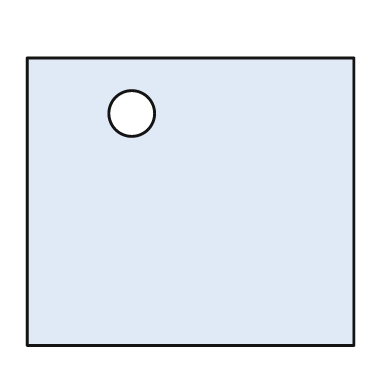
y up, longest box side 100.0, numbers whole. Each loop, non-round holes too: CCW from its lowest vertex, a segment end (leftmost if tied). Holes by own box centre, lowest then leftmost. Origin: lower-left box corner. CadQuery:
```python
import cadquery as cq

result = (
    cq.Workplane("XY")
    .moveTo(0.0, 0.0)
    .lineTo(100.0, 0.0)
    .lineTo(100.0, 88.0)
    .lineTo(0.0, 88.0)
    .close()
    .moveTo(32.0, 71.0)
    .circle(7.0)
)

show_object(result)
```